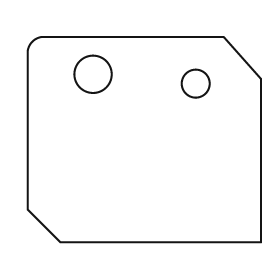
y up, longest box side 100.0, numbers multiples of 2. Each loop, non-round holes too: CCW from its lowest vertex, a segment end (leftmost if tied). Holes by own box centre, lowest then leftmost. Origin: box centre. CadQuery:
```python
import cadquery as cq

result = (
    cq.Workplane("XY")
    .moveTo(-36.0, -44.0)
    .lineTo(50.0, -44.0)
    .lineTo(50.0, 26.0)
    .lineTo(34.0, 44.0)
    .lineTo(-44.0, 44.0)
    .threePointArc((-48.0, 42.0), (-50.0, 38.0))
    .lineTo(-50.0, -30.0)
    .close()
    .moveTo(22.0, 24.0)
    .circle(6.0)
    .moveTo(-22.0, 28.0)
    .circle(8.0)
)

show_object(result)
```